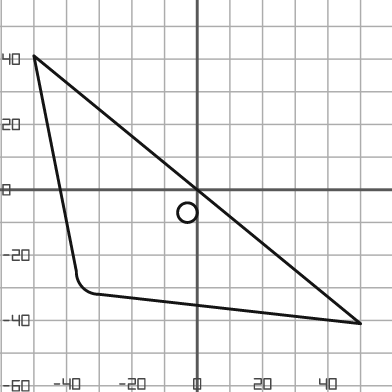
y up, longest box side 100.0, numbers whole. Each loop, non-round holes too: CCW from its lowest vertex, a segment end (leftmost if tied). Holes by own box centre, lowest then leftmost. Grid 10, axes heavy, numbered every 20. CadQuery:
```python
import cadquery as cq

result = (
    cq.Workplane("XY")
    .moveTo(50.0, -41.0)
    .lineTo(-50.0, 41.0)
    .lineTo(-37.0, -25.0)
    .threePointArc((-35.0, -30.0), (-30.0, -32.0))
    .close()
    .moveTo(-3.0, -7.0)
    .circle(3.0)
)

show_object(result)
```